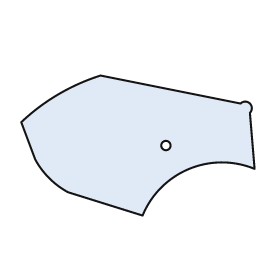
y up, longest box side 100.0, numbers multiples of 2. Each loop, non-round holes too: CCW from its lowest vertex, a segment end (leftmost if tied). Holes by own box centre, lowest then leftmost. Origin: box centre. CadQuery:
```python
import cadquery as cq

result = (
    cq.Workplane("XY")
    .moveTo(2.0, -30.0)
    .threePointArc((22.0, -10.0), (50.0, -10.0))
    .lineTo(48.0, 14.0)
    .threePointArc((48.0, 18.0), (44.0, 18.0))
    .lineTo(-16.0, 30.0)
    .threePointArc((-34.0, 22.0), (-50.0, 10.0))
    .lineTo(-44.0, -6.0)
    .threePointArc((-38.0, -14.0), (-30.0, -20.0))
    .close()
    .moveTo(12.0, 0.0)
    .circle(2.0)
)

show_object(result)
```